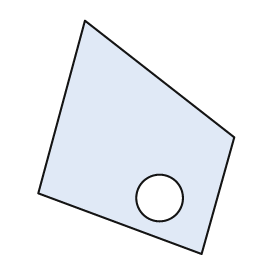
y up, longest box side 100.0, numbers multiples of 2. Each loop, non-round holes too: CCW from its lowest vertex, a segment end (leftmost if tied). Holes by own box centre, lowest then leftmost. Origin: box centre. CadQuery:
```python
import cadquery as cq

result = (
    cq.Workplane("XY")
    .moveTo(28.0, -50.0)
    .lineTo(42.0, 0.0)
    .lineTo(-22.0, 50.0)
    .lineTo(-42.0, -24.0)
    .close()
    .moveTo(10.0, -26.0)
    .circle(10.0)
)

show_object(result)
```